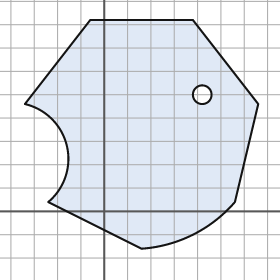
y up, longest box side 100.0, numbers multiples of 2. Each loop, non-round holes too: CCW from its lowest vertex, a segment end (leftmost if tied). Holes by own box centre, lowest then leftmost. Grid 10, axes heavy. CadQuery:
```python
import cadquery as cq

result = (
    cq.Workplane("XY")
    .moveTo(16.0, -16.0)
    .threePointArc((38.0, -10.0), (56.0, 4.0))
    .lineTo(66.0, 46.0)
    .lineTo(38.0, 82.0)
    .lineTo(-6.0, 82.0)
    .lineTo(-34.0, 46.0)
    .threePointArc((-16.0, 28.0), (-24.0, 4.0))
    .close()
    .moveTo(42.0, 50.0)
    .circle(4.0)
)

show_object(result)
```